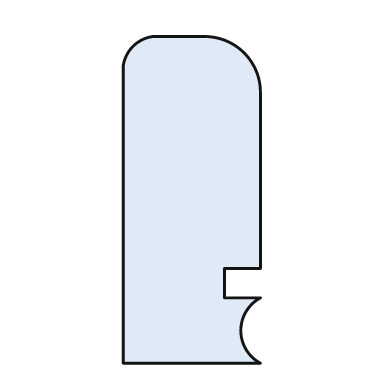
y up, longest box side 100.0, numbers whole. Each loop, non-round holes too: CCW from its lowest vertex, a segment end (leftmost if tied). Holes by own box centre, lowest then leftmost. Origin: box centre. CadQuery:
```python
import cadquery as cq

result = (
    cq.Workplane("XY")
    .moveTo(-21.0, -50.0)
    .lineTo(21.0, -50.0)
    .threePointArc((15.0, -40.0), (21.0, -30.0))
    .lineTo(10.0, -30.0)
    .lineTo(10.0, -21.0)
    .lineTo(21.0, -21.0)
    .lineTo(21.0, 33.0)
    .threePointArc((16.0, 45.0), (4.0, 50.0))
    .lineTo(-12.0, 50.0)
    .threePointArc((-18.0, 47.0), (-21.0, 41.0))
    .close()
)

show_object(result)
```